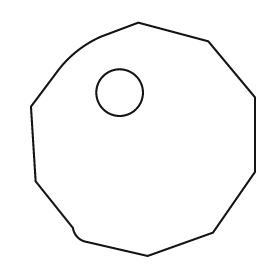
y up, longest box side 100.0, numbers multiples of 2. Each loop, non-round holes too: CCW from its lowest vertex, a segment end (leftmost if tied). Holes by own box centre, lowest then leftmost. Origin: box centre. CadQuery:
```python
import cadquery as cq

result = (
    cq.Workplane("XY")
    .moveTo(2.0, -50.0)
    .lineTo(30.0, -40.0)
    .lineTo(48.0, -14.0)
    .lineTo(48.0, 18.0)
    .lineTo(28.0, 42.0)
    .lineTo(-2.0, 50.0)
    .lineTo(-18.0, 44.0)
    .threePointArc((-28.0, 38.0), (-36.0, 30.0))
    .lineTo(-48.0, 14.0)
    .lineTo(-46.0, -18.0)
    .lineTo(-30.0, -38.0)
    .threePointArc((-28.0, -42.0), (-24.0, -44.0))
    .close()
    .moveTo(-10.0, 20.0)
    .circle(10.0)
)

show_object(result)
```